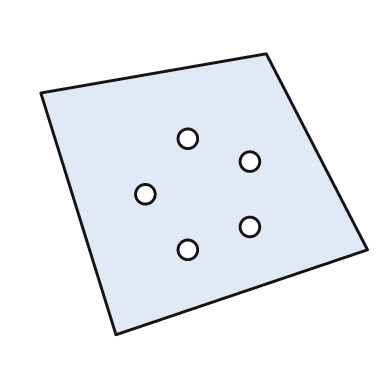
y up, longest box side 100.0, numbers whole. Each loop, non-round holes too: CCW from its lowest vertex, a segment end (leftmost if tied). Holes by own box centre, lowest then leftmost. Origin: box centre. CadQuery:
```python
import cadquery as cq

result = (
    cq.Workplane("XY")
    .moveTo(-27.0, -43.0)
    .lineTo(50.0, -17.0)
    .lineTo(19.0, 43.0)
    .lineTo(-50.0, 31.0)
    .close()
    .moveTo(-5.0, -17.0)
    .circle(3.0)
    .moveTo(14.0, -10.0)
    .circle(3.0)
    .moveTo(-18.0, 0.0)
    .circle(3.0)
    .moveTo(14.0, 10.0)
    .circle(3.0)
    .moveTo(-5.0, 17.0)
    .circle(3.0)
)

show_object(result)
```